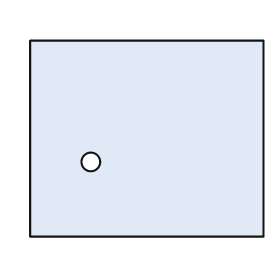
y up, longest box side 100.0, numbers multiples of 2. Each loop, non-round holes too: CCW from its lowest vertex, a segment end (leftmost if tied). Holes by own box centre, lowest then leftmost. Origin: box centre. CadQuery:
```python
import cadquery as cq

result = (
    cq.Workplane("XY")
    .moveTo(-50.0, -42.0)
    .lineTo(50.0, -42.0)
    .lineTo(50.0, 42.0)
    .lineTo(-50.0, 42.0)
    .close()
    .moveTo(-24.0, -10.0)
    .circle(4.0)
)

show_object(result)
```